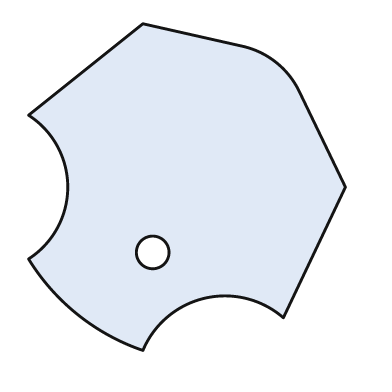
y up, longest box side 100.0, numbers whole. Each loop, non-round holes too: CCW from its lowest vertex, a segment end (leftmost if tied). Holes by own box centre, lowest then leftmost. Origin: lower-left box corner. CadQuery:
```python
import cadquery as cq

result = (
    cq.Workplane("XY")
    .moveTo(35.0, 0.0)
    .threePointArc((54.0, 16.0), (78.0, 10.0))
    .lineTo(97.0, 50.0)
    .lineTo(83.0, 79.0)
    .threePointArc((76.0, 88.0), (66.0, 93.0))
    .lineTo(35.0, 100.0)
    .lineTo(0.0, 72.0)
    .threePointArc((12.0, 50.0), (0.0, 28.0))
    .threePointArc((15.0, 11.0), (35.0, 0.0))
    .close()
    .moveTo(38.0, 30.0)
    .circle(5.0)
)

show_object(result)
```